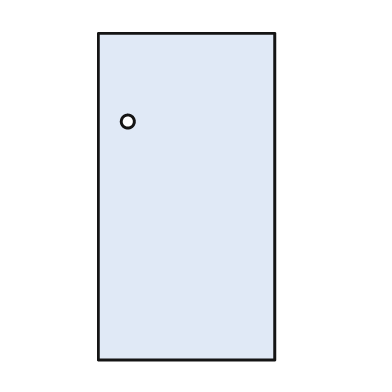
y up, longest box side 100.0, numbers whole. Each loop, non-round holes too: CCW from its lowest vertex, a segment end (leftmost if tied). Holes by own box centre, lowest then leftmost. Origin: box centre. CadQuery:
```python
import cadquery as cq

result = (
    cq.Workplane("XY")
    .moveTo(-27.0, -50.0)
    .lineTo(27.0, -50.0)
    .lineTo(27.0, 50.0)
    .lineTo(-27.0, 50.0)
    .close()
    .moveTo(-18.0, 23.0)
    .circle(2.0)
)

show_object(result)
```